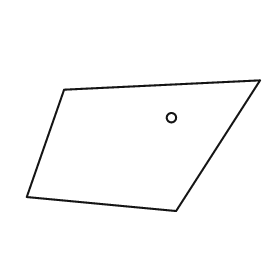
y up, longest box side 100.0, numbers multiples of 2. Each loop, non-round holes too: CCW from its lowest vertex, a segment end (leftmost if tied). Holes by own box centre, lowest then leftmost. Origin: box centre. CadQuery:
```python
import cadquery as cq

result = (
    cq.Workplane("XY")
    .moveTo(14.0, -28.0)
    .lineTo(50.0, 28.0)
    .lineTo(-34.0, 24.0)
    .lineTo(-50.0, -22.0)
    .close()
    .moveTo(12.0, 12.0)
    .circle(2.0)
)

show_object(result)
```